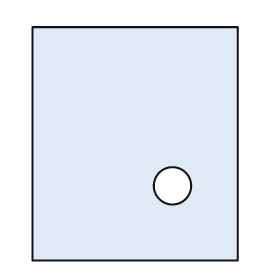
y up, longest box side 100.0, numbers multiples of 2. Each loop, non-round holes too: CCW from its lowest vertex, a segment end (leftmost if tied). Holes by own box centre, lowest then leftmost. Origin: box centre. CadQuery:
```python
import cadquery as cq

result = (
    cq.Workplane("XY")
    .moveTo(-44.0, -50.0)
    .lineTo(44.0, -50.0)
    .lineTo(44.0, 50.0)
    .lineTo(-44.0, 50.0)
    .close()
    .moveTo(16.0, -18.0)
    .circle(8.0)
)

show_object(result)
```